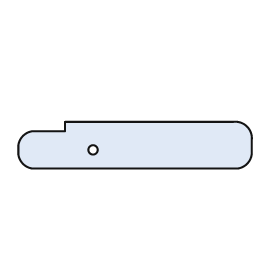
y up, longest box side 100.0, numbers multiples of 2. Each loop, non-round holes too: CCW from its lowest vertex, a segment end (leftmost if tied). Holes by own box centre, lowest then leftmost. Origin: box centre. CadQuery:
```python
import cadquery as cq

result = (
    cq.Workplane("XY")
    .moveTo(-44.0, -10.0)
    .lineTo(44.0, -10.0)
    .threePointArc((48.0, -8.0), (50.0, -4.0))
    .lineTo(50.0, 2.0)
    .threePointArc((48.0, 8.0), (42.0, 10.0))
    .lineTo(-30.0, 10.0)
    .lineTo(-30.0, 6.0)
    .lineTo(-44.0, 6.0)
    .threePointArc((-48.0, 4.0), (-50.0, 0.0))
    .lineTo(-50.0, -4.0)
    .threePointArc((-48.0, -8.0), (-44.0, -10.0))
    .close()
    .moveTo(-18.0, -2.0)
    .circle(2.0)
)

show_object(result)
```